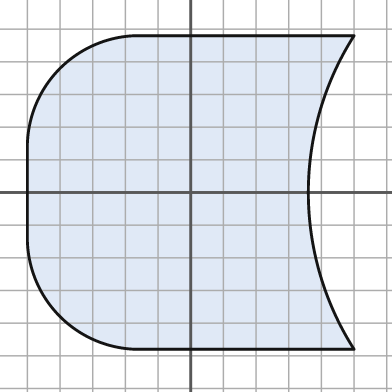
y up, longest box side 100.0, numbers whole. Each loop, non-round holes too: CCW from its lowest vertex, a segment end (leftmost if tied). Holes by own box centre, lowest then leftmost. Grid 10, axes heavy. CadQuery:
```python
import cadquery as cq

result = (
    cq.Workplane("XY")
    .moveTo(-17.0, -48.0)
    .lineTo(50.0, -48.0)
    .threePointArc((36.0, 0.0), (50.0, 48.0))
    .lineTo(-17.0, 48.0)
    .threePointArc((-40.0, 38.0), (-50.0, 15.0))
    .lineTo(-50.0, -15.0)
    .threePointArc((-40.0, -38.0), (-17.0, -48.0))
    .close()
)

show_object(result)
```